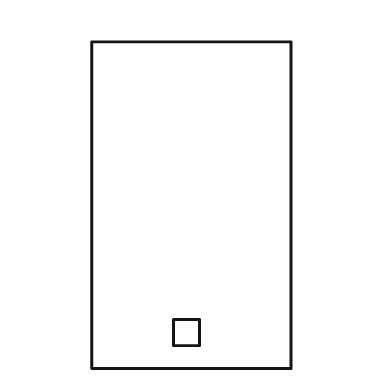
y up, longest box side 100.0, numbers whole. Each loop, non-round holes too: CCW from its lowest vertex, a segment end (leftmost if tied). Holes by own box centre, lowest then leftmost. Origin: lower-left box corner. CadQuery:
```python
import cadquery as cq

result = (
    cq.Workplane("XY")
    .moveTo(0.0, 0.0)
    .lineTo(61.0, 0.0)
    .lineTo(61.0, 100.0)
    .lineTo(0.0, 100.0)
    .close()
    .moveTo(25.0, 7.0)
    .lineTo(33.0, 7.0)
    .lineTo(33.0, 15.0)
    .lineTo(25.0, 15.0)
    .close()
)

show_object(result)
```